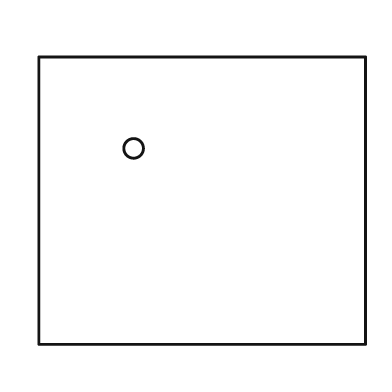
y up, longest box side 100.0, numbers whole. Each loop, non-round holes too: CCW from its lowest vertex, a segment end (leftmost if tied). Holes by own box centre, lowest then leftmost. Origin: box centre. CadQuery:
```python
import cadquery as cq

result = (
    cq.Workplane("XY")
    .moveTo(-50.0, -44.0)
    .lineTo(50.0, -44.0)
    .lineTo(50.0, 44.0)
    .lineTo(-50.0, 44.0)
    .close()
    .moveTo(-21.0, 16.0)
    .circle(3.0)
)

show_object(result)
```